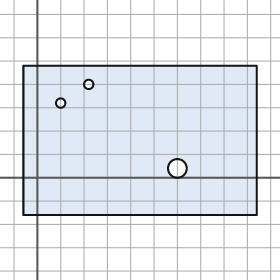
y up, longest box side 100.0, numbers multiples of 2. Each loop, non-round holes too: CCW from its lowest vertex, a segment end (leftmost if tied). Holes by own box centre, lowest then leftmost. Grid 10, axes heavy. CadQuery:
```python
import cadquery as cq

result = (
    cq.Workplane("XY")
    .moveTo(-6.0, -16.0)
    .lineTo(94.0, -16.0)
    .lineTo(94.0, 48.0)
    .lineTo(-6.0, 48.0)
    .close()
    .moveTo(60.0, 4.0)
    .circle(4.0)
    .moveTo(10.0, 32.0)
    .circle(2.0)
    .moveTo(22.0, 40.0)
    .circle(2.0)
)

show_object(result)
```